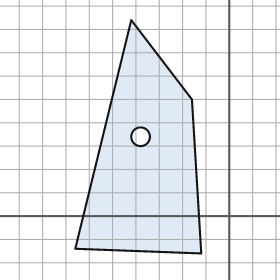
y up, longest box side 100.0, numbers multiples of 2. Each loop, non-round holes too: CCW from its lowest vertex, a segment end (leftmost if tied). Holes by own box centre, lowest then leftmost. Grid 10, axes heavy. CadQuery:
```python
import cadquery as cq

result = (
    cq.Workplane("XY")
    .moveTo(-12.0, -16.0)
    .lineTo(-16.0, 50.0)
    .lineTo(-42.0, 84.0)
    .lineTo(-66.0, -14.0)
    .close()
    .moveTo(-38.0, 34.0)
    .circle(4.0)
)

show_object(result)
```